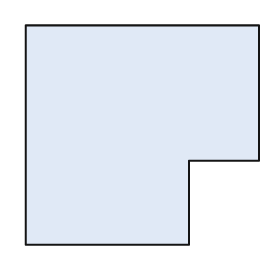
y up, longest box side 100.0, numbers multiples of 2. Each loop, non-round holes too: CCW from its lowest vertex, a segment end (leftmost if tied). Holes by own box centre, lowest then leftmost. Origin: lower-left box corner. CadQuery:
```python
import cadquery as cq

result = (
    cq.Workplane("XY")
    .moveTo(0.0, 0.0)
    .lineTo(70.0, 0.0)
    .lineTo(70.0, 36.0)
    .lineTo(100.0, 36.0)
    .lineTo(100.0, 94.0)
    .lineTo(0.0, 94.0)
    .close()
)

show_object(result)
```